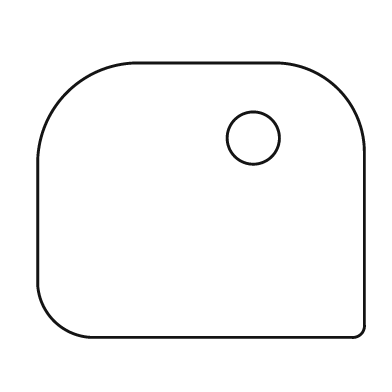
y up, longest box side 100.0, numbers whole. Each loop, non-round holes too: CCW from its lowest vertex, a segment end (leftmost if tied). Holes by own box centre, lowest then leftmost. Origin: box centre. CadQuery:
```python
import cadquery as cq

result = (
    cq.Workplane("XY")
    .moveTo(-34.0, -42.0)
    .lineTo(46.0, -42.0)
    .threePointArc((49.0, -41.0), (50.0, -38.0))
    .lineTo(50.0, 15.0)
    .threePointArc((42.0, 34.0), (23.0, 42.0))
    .lineTo(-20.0, 42.0)
    .threePointArc((-41.0, 33.0), (-50.0, 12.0))
    .lineTo(-50.0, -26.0)
    .threePointArc((-45.0, -37.0), (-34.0, -42.0))
    .close()
    .moveTo(16.0, 19.0)
    .circle(8.0)
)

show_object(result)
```